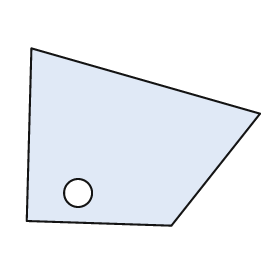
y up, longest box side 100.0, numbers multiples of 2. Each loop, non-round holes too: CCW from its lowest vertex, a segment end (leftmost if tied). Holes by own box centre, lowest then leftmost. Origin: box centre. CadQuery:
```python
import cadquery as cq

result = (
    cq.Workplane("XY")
    .moveTo(12.0, -38.0)
    .lineTo(50.0, 10.0)
    .lineTo(-48.0, 38.0)
    .lineTo(-50.0, -36.0)
    .close()
    .moveTo(-28.0, -24.0)
    .circle(6.0)
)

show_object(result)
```